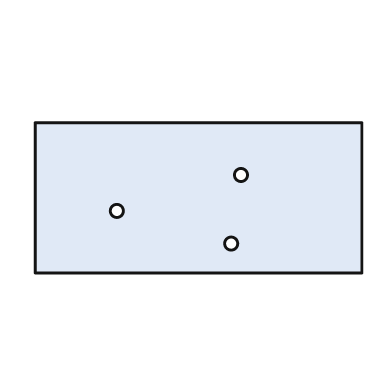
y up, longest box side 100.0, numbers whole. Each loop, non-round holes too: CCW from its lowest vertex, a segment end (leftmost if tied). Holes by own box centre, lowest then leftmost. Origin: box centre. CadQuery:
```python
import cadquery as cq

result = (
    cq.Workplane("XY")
    .moveTo(-50.0, -23.0)
    .lineTo(50.0, -23.0)
    .lineTo(50.0, 23.0)
    .lineTo(-50.0, 23.0)
    .close()
    .moveTo(10.0, -14.0)
    .circle(2.0)
    .moveTo(-25.0, -4.0)
    .circle(2.0)
    .moveTo(13.0, 7.0)
    .circle(2.0)
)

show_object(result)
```